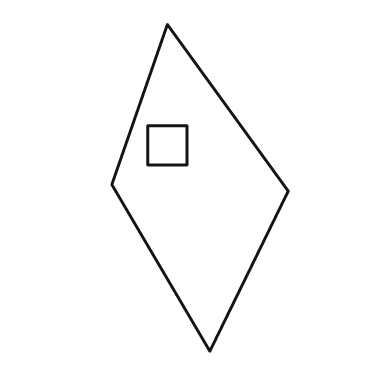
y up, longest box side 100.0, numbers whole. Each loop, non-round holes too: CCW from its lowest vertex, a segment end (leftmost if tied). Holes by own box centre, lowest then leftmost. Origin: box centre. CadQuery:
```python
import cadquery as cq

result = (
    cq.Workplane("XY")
    .moveTo(3.0, -50.0)
    .lineTo(27.0, -1.0)
    .lineTo(-10.0, 50.0)
    .lineTo(-27.0, 1.0)
    .close()
    .moveTo(-16.0, 7.0)
    .lineTo(-4.0, 7.0)
    .lineTo(-4.0, 19.0)
    .lineTo(-16.0, 19.0)
    .close()
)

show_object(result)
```